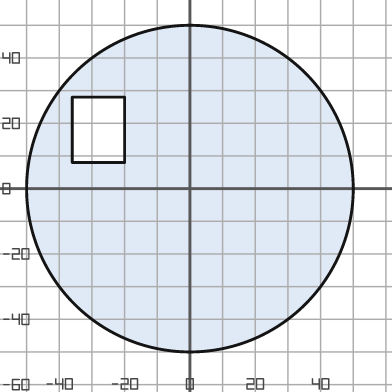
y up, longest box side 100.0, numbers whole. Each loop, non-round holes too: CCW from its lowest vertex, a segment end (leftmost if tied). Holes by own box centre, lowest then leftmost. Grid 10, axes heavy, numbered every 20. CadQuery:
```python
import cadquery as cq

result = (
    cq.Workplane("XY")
    .moveTo(0.0, 0.0)
    .circle(50.0)
    .moveTo(-36.0, 8.0)
    .lineTo(-20.0, 8.0)
    .lineTo(-20.0, 28.0)
    .lineTo(-36.0, 28.0)
    .close()
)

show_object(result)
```